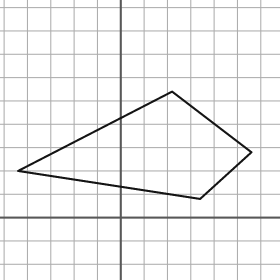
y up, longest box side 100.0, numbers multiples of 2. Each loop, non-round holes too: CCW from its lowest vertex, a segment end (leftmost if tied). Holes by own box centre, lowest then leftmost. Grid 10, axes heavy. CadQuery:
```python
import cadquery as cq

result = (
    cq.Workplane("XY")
    .moveTo(34.0, 8.0)
    .lineTo(56.0, 28.0)
    .lineTo(22.0, 54.0)
    .lineTo(-44.0, 20.0)
    .close()
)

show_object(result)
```